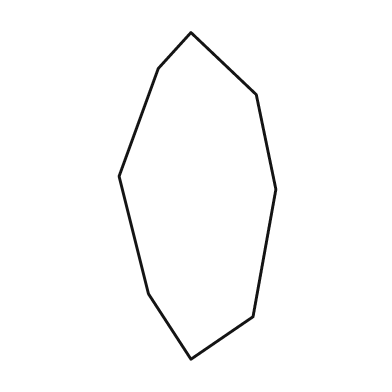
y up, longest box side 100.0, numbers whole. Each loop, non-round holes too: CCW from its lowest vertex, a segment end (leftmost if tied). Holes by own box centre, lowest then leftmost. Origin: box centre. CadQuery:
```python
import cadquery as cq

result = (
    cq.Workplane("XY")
    .moveTo(-2.0, -50.0)
    .lineTo(17.0, -37.0)
    .lineTo(24.0, 2.0)
    .lineTo(18.0, 31.0)
    .lineTo(-2.0, 50.0)
    .lineTo(-12.0, 39.0)
    .lineTo(-24.0, 6.0)
    .lineTo(-15.0, -30.0)
    .close()
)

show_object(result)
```